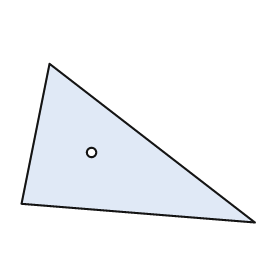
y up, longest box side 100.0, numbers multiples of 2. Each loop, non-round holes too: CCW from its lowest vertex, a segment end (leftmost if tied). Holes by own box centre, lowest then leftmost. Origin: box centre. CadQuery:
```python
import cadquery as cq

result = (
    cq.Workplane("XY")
    .moveTo(50.0, -34.0)
    .lineTo(-38.0, 34.0)
    .lineTo(-50.0, -26.0)
    .close()
    .moveTo(-20.0, -4.0)
    .circle(2.0)
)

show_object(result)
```